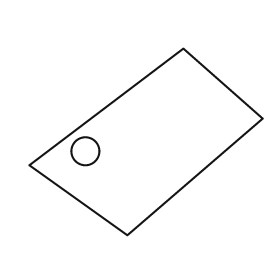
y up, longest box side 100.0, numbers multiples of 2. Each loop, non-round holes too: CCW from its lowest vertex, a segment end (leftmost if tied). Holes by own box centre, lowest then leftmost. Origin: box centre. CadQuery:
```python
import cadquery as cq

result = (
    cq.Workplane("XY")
    .moveTo(-8.0, -40.0)
    .lineTo(50.0, 10.0)
    .lineTo(16.0, 40.0)
    .lineTo(-50.0, -10.0)
    .close()
    .moveTo(-26.0, -4.0)
    .circle(6.0)
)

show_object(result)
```